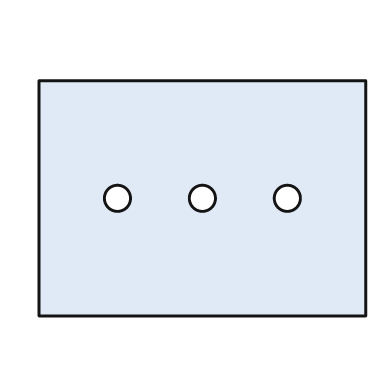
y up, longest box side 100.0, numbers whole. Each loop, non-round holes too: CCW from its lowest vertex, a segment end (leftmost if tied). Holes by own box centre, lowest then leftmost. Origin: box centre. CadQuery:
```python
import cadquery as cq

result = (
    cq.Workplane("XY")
    .moveTo(-50.0, -36.0)
    .lineTo(50.0, -36.0)
    .lineTo(50.0, 36.0)
    .lineTo(-50.0, 36.0)
    .close()
    .moveTo(-26.0, 0.0)
    .circle(4.0)
    .moveTo(0.0, 0.0)
    .circle(4.0)
    .moveTo(26.0, 0.0)
    .circle(4.0)
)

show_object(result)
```